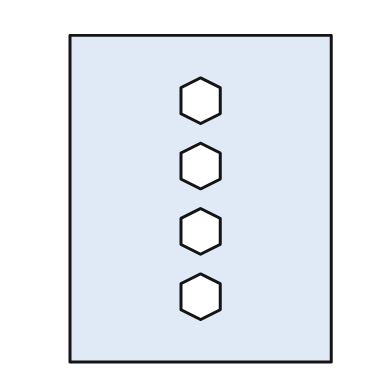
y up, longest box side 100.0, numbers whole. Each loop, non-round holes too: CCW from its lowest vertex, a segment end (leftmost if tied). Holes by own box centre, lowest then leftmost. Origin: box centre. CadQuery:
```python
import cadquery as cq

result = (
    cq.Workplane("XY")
    .moveTo(-40.0, -50.0)
    .lineTo(40.0, -50.0)
    .lineTo(40.0, 50.0)
    .lineTo(-40.0, 50.0)
    .close()
    .moveTo(0.0, -37.0)
    .lineTo(6.0, -34.0)
    .lineTo(6.0, -26.0)
    .lineTo(0.0, -23.0)
    .lineTo(-6.0, -26.0)
    .lineTo(-6.0, -34.0)
    .close()
    .moveTo(0.0, -17.0)
    .lineTo(6.0, -14.0)
    .lineTo(6.0, -6.0)
    .lineTo(0.0, -3.0)
    .lineTo(-6.0, -6.0)
    .lineTo(-6.0, -14.0)
    .close()
    .moveTo(0.0, 3.0)
    .lineTo(6.0, 6.0)
    .lineTo(6.0, 14.0)
    .lineTo(0.0, 17.0)
    .lineTo(-6.0, 14.0)
    .lineTo(-6.0, 6.0)
    .close()
    .moveTo(0.0, 23.0)
    .lineTo(6.0, 26.0)
    .lineTo(6.0, 34.0)
    .lineTo(0.0, 37.0)
    .lineTo(-6.0, 34.0)
    .lineTo(-6.0, 26.0)
    .close()
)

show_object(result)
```